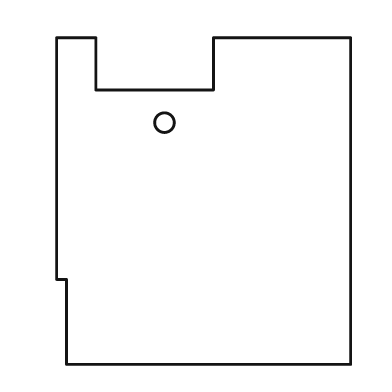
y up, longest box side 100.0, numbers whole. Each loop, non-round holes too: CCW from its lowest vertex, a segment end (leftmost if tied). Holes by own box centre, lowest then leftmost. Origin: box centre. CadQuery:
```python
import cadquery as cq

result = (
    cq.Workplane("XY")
    .moveTo(-42.0, -50.0)
    .lineTo(45.0, -50.0)
    .lineTo(45.0, 50.0)
    .lineTo(3.0, 50.0)
    .lineTo(3.0, 34.0)
    .lineTo(-33.0, 34.0)
    .lineTo(-33.0, 50.0)
    .lineTo(-45.0, 50.0)
    .lineTo(-45.0, -24.0)
    .lineTo(-42.0, -24.0)
    .close()
    .moveTo(-12.0, 24.0)
    .circle(3.0)
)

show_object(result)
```